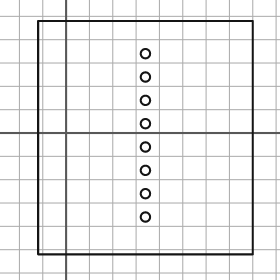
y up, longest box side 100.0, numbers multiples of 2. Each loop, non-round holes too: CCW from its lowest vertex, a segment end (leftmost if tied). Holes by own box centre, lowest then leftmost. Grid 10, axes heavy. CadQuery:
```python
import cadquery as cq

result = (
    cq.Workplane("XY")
    .moveTo(-12.0, -52.0)
    .lineTo(80.0, -52.0)
    .lineTo(80.0, 48.0)
    .lineTo(-12.0, 48.0)
    .close()
    .moveTo(34.0, -36.0)
    .circle(2.0)
    .moveTo(34.0, -26.0)
    .circle(2.0)
    .moveTo(34.0, -16.0)
    .circle(2.0)
    .moveTo(34.0, -6.0)
    .circle(2.0)
    .moveTo(34.0, 4.0)
    .circle(2.0)
    .moveTo(34.0, 14.0)
    .circle(2.0)
    .moveTo(34.0, 24.0)
    .circle(2.0)
    .moveTo(34.0, 34.0)
    .circle(2.0)
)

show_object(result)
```